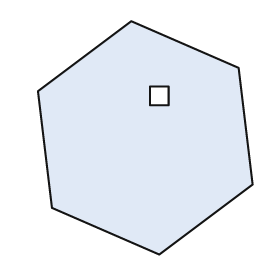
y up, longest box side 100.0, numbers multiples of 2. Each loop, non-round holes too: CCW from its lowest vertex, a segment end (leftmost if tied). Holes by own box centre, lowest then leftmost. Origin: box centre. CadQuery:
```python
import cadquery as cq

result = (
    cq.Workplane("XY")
    .moveTo(6.0, -50.0)
    .lineTo(46.0, -20.0)
    .lineTo(40.0, 30.0)
    .lineTo(-6.0, 50.0)
    .lineTo(-46.0, 20.0)
    .lineTo(-40.0, -30.0)
    .close()
    .moveTo(2.0, 14.0)
    .lineTo(10.0, 14.0)
    .lineTo(10.0, 22.0)
    .lineTo(2.0, 22.0)
    .close()
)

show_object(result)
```